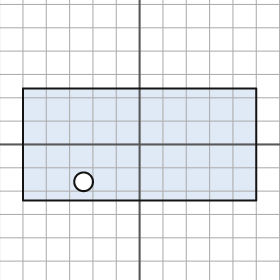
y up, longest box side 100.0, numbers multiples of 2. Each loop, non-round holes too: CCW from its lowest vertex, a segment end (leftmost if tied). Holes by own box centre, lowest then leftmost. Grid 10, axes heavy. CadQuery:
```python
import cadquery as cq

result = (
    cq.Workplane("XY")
    .moveTo(-50.0, -24.0)
    .lineTo(50.0, -24.0)
    .lineTo(50.0, 24.0)
    .lineTo(-50.0, 24.0)
    .close()
    .moveTo(-24.0, -16.0)
    .circle(4.0)
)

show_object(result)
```